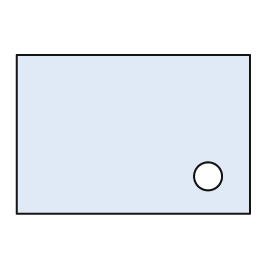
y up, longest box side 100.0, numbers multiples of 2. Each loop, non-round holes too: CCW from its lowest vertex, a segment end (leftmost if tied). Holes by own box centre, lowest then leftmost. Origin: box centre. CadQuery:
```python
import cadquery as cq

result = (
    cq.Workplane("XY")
    .moveTo(-50.0, -34.0)
    .lineTo(50.0, -34.0)
    .lineTo(50.0, 34.0)
    .lineTo(-50.0, 34.0)
    .close()
    .moveTo(32.0, -18.0)
    .circle(6.0)
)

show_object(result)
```